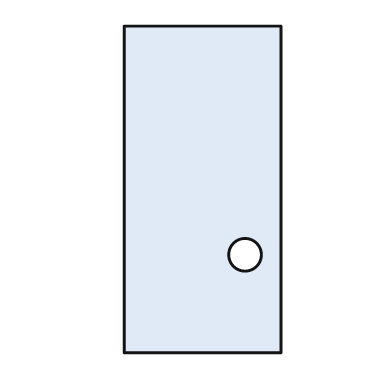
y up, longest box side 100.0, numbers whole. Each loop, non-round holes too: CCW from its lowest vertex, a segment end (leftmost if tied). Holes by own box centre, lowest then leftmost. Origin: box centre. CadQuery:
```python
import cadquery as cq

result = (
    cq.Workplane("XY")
    .moveTo(-24.0, -50.0)
    .lineTo(24.0, -50.0)
    .lineTo(24.0, 50.0)
    .lineTo(-24.0, 50.0)
    .close()
    .moveTo(13.0, -20.0)
    .circle(5.0)
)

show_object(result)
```